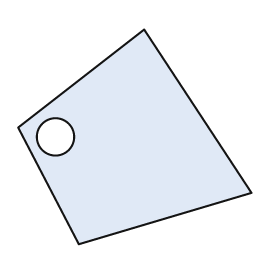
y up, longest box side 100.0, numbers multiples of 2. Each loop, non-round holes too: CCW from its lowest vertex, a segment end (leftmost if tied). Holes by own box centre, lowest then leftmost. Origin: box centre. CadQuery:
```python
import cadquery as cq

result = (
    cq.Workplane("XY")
    .moveTo(-24.0, -46.0)
    .lineTo(50.0, -24.0)
    .lineTo(4.0, 46.0)
    .lineTo(-50.0, 4.0)
    .close()
    .moveTo(-34.0, 0.0)
    .circle(8.0)
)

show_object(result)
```